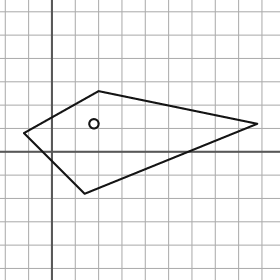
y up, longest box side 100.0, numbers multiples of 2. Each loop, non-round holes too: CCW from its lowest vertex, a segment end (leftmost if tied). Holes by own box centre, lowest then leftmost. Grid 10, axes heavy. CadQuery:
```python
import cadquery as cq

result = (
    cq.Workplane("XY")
    .moveTo(14.0, -18.0)
    .lineTo(88.0, 12.0)
    .lineTo(20.0, 26.0)
    .lineTo(-12.0, 8.0)
    .close()
    .moveTo(18.0, 12.0)
    .circle(2.0)
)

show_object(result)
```